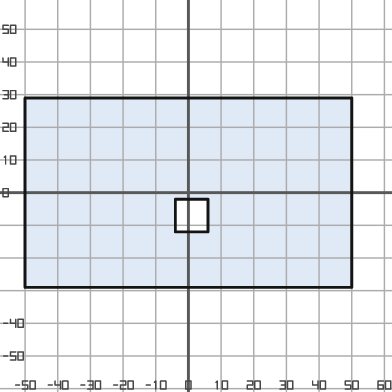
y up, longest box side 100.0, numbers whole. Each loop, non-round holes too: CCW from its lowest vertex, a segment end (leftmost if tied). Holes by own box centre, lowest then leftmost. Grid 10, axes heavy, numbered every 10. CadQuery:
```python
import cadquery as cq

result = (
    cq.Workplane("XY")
    .moveTo(-50.0, -29.0)
    .lineTo(50.0, -29.0)
    .lineTo(50.0, 29.0)
    .lineTo(-50.0, 29.0)
    .close()
    .moveTo(-4.0, -12.0)
    .lineTo(6.0, -12.0)
    .lineTo(6.0, -2.0)
    .lineTo(-4.0, -2.0)
    .close()
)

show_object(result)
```